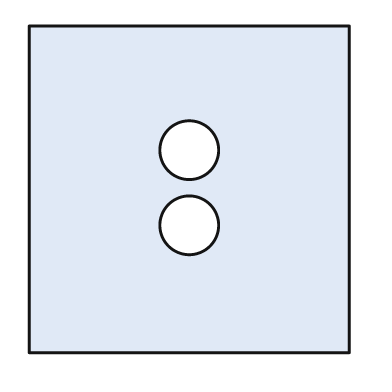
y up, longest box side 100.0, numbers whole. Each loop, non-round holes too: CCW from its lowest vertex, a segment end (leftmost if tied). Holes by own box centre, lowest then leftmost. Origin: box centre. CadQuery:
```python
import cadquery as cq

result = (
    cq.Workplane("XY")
    .moveTo(-49.0, -50.0)
    .lineTo(49.0, -50.0)
    .lineTo(49.0, 50.0)
    .lineTo(-49.0, 50.0)
    .close()
    .moveTo(0.0, -11.0)
    .circle(9.0)
    .moveTo(0.0, 12.0)
    .circle(9.0)
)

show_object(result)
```